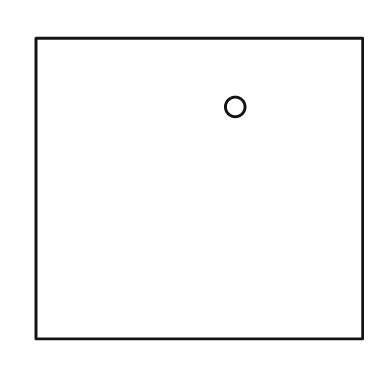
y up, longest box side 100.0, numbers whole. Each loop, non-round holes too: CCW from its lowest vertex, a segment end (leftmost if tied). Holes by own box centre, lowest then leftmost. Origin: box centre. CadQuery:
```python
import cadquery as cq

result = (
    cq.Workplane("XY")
    .moveTo(-50.0, -46.0)
    .lineTo(50.0, -46.0)
    .lineTo(50.0, 46.0)
    .lineTo(-50.0, 46.0)
    .close()
    .moveTo(11.0, 25.0)
    .circle(3.0)
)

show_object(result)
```